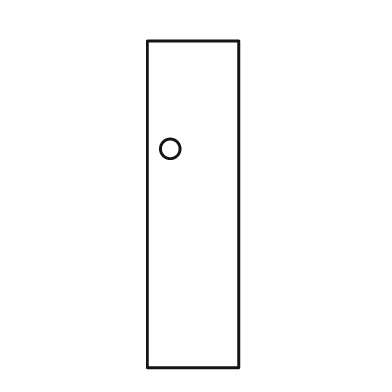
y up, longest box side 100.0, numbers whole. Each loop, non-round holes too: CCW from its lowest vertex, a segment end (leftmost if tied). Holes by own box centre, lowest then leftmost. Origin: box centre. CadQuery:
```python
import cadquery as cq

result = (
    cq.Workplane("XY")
    .moveTo(-14.0, -50.0)
    .lineTo(14.0, -50.0)
    .lineTo(14.0, 50.0)
    .lineTo(-14.0, 50.0)
    .close()
    .moveTo(-7.0, 17.0)
    .circle(3.0)
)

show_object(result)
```